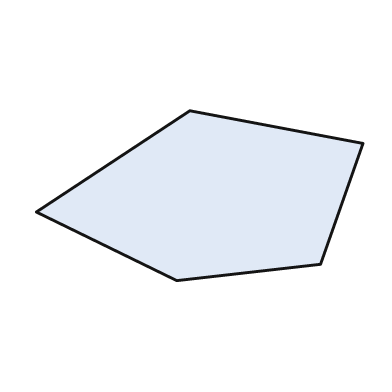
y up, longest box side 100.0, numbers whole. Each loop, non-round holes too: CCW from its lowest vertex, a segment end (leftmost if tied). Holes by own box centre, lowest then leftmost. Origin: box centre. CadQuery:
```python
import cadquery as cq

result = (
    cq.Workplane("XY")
    .moveTo(-7.0, -26.0)
    .lineTo(37.0, -21.0)
    .lineTo(50.0, 16.0)
    .lineTo(-3.0, 26.0)
    .lineTo(-50.0, -5.0)
    .close()
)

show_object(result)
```